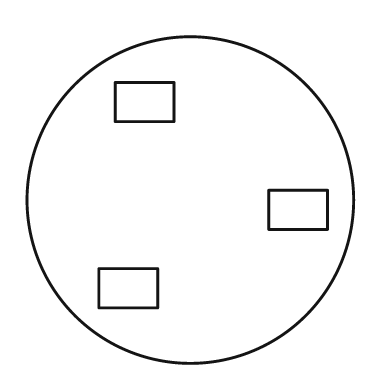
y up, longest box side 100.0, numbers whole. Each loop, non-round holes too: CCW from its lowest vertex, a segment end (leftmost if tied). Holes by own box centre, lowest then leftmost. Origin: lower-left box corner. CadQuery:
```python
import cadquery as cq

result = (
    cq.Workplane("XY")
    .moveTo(50.0, 50.0)
    .circle(50.0)
    .moveTo(22.0, 17.0)
    .lineTo(40.0, 17.0)
    .lineTo(40.0, 29.0)
    .lineTo(22.0, 29.0)
    .close()
    .moveTo(74.0, 41.0)
    .lineTo(92.0, 41.0)
    .lineTo(92.0, 53.0)
    .lineTo(74.0, 53.0)
    .close()
    .moveTo(27.0, 74.0)
    .lineTo(45.0, 74.0)
    .lineTo(45.0, 86.0)
    .lineTo(27.0, 86.0)
    .close()
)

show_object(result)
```